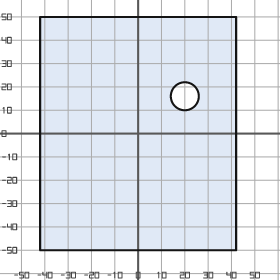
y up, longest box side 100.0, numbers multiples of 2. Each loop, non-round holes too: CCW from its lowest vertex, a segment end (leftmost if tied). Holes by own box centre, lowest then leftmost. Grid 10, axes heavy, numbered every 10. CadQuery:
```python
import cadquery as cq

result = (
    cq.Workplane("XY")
    .moveTo(-42.0, -50.0)
    .lineTo(42.0, -50.0)
    .lineTo(42.0, 50.0)
    .lineTo(-42.0, 50.0)
    .close()
    .moveTo(20.0, 16.0)
    .circle(6.0)
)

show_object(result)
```